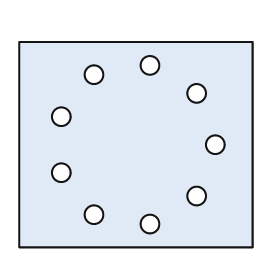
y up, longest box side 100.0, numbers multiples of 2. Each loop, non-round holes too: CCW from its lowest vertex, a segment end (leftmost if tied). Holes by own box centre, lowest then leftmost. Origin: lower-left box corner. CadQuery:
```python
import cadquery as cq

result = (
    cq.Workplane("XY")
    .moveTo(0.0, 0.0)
    .lineTo(100.0, 0.0)
    .lineTo(100.0, 88.0)
    .lineTo(0.0, 88.0)
    .close()
    .moveTo(56.0, 10.0)
    .circle(4.0)
    .moveTo(32.0, 14.0)
    .circle(4.0)
    .moveTo(76.0, 22.0)
    .circle(4.0)
    .moveTo(18.0, 32.0)
    .circle(4.0)
    .moveTo(84.0, 44.0)
    .circle(4.0)
    .moveTo(18.0, 56.0)
    .circle(4.0)
    .moveTo(76.0, 66.0)
    .circle(4.0)
    .moveTo(32.0, 74.0)
    .circle(4.0)
    .moveTo(56.0, 78.0)
    .circle(4.0)
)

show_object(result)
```